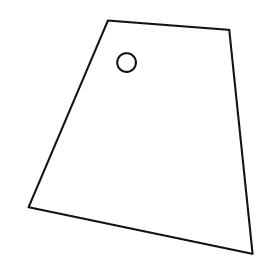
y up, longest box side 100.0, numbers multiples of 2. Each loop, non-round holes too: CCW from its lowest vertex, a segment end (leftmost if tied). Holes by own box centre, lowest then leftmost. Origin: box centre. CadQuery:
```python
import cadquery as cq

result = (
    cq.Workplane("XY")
    .moveTo(48.0, -50.0)
    .lineTo(38.0, 46.0)
    .lineTo(-14.0, 50.0)
    .lineTo(-48.0, -30.0)
    .close()
    .moveTo(-6.0, 32.0)
    .circle(4.0)
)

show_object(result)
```